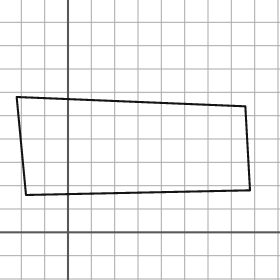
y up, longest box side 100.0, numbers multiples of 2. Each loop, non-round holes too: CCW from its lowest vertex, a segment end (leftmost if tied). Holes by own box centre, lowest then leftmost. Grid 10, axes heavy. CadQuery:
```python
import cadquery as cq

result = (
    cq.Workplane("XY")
    .moveTo(-18.0, 16.0)
    .lineTo(78.0, 18.0)
    .lineTo(76.0, 54.0)
    .lineTo(-22.0, 58.0)
    .close()
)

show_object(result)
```